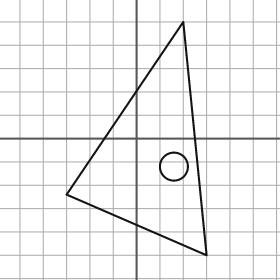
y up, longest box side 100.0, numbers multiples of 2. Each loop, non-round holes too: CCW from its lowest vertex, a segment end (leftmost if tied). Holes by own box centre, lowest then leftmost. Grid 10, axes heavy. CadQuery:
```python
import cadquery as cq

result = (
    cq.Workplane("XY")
    .moveTo(30.0, -50.0)
    .lineTo(20.0, 50.0)
    .lineTo(-30.0, -24.0)
    .close()
    .moveTo(16.0, -12.0)
    .circle(6.0)
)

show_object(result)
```